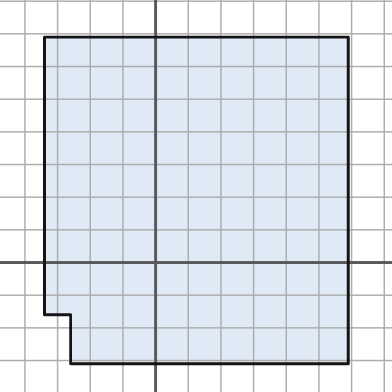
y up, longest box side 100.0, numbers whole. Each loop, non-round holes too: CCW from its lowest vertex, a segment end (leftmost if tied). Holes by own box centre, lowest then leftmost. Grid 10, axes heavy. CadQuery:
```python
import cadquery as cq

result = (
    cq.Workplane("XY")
    .moveTo(-26.0, -31.0)
    .lineTo(59.0, -31.0)
    .lineTo(59.0, 69.0)
    .lineTo(-34.0, 69.0)
    .lineTo(-34.0, -16.0)
    .lineTo(-26.0, -16.0)
    .close()
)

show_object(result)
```